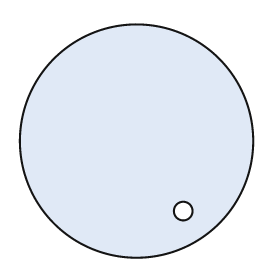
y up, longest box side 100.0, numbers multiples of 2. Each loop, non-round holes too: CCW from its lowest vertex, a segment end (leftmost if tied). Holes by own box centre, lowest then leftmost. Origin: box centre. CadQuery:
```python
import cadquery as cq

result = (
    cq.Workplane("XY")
    .moveTo(0.0, 0.0)
    .circle(50.0)
    .moveTo(20.0, -30.0)
    .circle(4.0)
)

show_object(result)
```